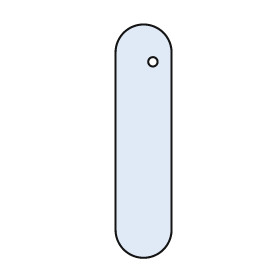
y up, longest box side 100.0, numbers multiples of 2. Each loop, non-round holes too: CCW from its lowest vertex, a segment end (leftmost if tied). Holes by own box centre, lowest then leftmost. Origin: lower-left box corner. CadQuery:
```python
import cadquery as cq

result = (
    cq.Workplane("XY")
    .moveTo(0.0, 12.0)
    .threePointArc((12.0, 0.0), (24.0, 12.0))
    .lineTo(24.0, 88.0)
    .threePointArc((12.0, 100.0), (0.0, 88.0))
    .close()
    .moveTo(16.0, 84.0)
    .circle(2.0)
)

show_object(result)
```